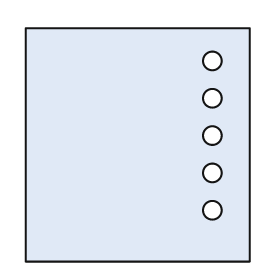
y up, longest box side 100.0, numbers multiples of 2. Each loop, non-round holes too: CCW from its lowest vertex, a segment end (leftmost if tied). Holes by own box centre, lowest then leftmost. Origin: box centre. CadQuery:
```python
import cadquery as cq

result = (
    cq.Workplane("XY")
    .moveTo(-48.0, -50.0)
    .lineTo(48.0, -50.0)
    .lineTo(48.0, 50.0)
    .lineTo(-48.0, 50.0)
    .close()
    .moveTo(32.0, -28.0)
    .circle(4.0)
    .moveTo(32.0, -12.0)
    .circle(4.0)
    .moveTo(32.0, 4.0)
    .circle(4.0)
    .moveTo(32.0, 20.0)
    .circle(4.0)
    .moveTo(32.0, 36.0)
    .circle(4.0)
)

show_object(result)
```